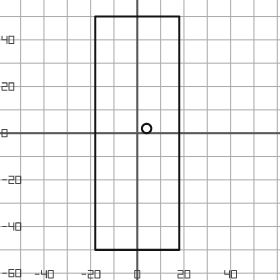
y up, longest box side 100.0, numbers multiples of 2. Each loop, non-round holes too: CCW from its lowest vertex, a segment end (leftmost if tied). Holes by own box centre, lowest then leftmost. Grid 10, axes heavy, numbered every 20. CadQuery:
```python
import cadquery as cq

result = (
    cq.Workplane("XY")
    .moveTo(-18.0, -50.0)
    .lineTo(18.0, -50.0)
    .lineTo(18.0, 50.0)
    .lineTo(-18.0, 50.0)
    .close()
    .moveTo(4.0, 2.0)
    .circle(2.0)
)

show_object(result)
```